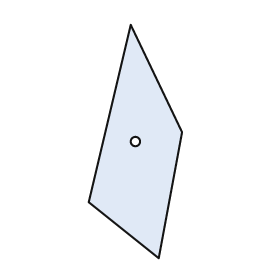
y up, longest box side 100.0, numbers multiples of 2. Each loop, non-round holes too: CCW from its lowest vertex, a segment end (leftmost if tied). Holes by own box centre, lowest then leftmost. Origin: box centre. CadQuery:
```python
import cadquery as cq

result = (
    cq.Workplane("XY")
    .moveTo(10.0, -50.0)
    .lineTo(20.0, 4.0)
    .lineTo(-2.0, 50.0)
    .lineTo(-20.0, -26.0)
    .close()
    .moveTo(0.0, 0.0)
    .circle(2.0)
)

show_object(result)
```